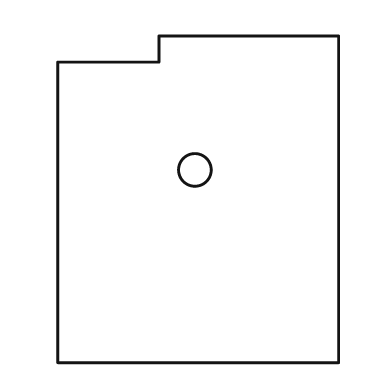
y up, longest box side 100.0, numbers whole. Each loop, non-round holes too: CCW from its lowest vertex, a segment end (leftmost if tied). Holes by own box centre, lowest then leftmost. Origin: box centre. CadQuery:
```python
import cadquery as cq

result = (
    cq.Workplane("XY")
    .moveTo(-43.0, -50.0)
    .lineTo(43.0, -50.0)
    .lineTo(43.0, 50.0)
    .lineTo(-12.0, 50.0)
    .lineTo(-12.0, 42.0)
    .lineTo(-43.0, 42.0)
    .close()
    .moveTo(-1.0, 9.0)
    .circle(5.0)
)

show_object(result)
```